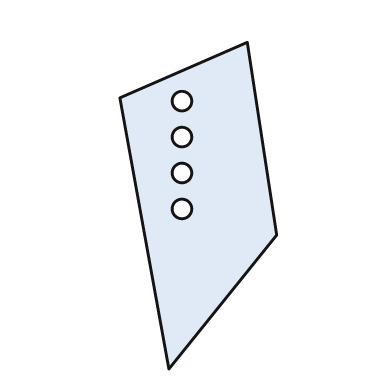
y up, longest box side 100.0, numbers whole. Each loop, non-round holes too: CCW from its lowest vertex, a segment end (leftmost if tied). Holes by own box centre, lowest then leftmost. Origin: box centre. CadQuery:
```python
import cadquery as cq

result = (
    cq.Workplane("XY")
    .moveTo(-9.0, -50.0)
    .lineTo(24.0, -9.0)
    .lineTo(15.0, 50.0)
    .lineTo(-24.0, 33.0)
    .close()
    .moveTo(-5.0, -1.0)
    .circle(3.0)
    .moveTo(-5.0, 10.0)
    .circle(3.0)
    .moveTo(-5.0, 21.0)
    .circle(3.0)
    .moveTo(-5.0, 32.0)
    .circle(3.0)
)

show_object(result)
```